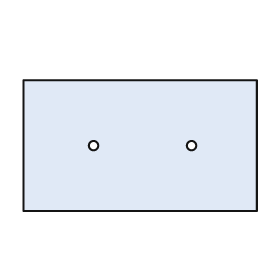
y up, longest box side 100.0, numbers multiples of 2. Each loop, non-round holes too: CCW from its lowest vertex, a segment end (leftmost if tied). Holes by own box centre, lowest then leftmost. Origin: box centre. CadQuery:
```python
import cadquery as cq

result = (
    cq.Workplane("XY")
    .moveTo(-50.0, -28.0)
    .lineTo(50.0, -28.0)
    .lineTo(50.0, 28.0)
    .lineTo(-50.0, 28.0)
    .close()
    .moveTo(-20.0, 0.0)
    .circle(2.0)
    .moveTo(22.0, 0.0)
    .circle(2.0)
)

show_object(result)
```